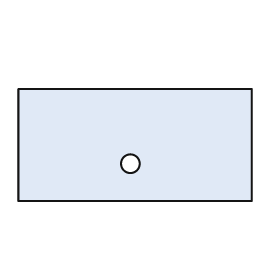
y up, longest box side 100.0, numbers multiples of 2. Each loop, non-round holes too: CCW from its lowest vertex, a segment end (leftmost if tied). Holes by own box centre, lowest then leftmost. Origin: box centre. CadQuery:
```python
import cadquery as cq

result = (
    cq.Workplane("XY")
    .moveTo(-50.0, -24.0)
    .lineTo(50.0, -24.0)
    .lineTo(50.0, 24.0)
    .lineTo(-50.0, 24.0)
    .close()
    .moveTo(-2.0, -8.0)
    .circle(4.0)
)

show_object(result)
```